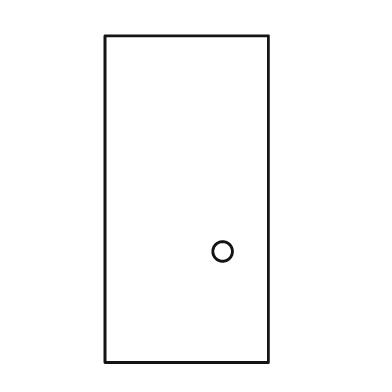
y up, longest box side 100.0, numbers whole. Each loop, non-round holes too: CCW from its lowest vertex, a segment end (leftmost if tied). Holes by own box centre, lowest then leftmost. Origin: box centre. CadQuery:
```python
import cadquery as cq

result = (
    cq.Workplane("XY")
    .moveTo(-25.0, -50.0)
    .lineTo(25.0, -50.0)
    .lineTo(25.0, 50.0)
    .lineTo(-25.0, 50.0)
    .close()
    .moveTo(11.0, -16.0)
    .circle(3.0)
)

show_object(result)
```